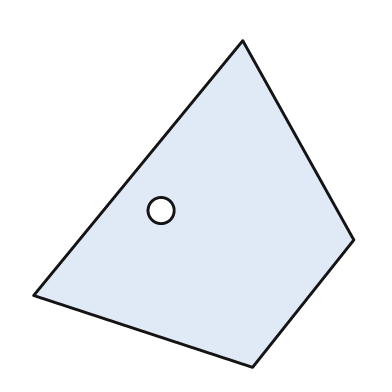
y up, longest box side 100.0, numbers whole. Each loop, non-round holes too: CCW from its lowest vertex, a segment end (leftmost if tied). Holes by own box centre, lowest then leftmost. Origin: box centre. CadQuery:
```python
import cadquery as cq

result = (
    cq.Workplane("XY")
    .moveTo(18.0, -50.0)
    .lineTo(49.0, -11.0)
    .lineTo(15.0, 50.0)
    .lineTo(-49.0, -28.0)
    .close()
    .moveTo(-10.0, -2.0)
    .circle(4.0)
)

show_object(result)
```